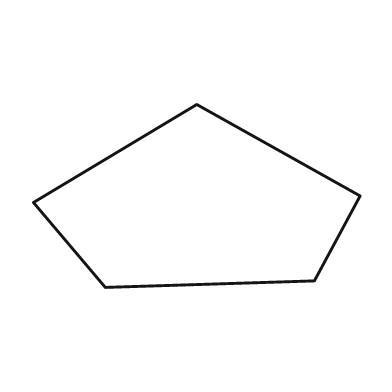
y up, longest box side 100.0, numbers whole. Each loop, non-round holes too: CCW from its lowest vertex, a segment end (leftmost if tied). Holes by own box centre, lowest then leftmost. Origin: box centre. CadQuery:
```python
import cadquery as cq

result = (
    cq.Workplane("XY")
    .moveTo(-28.0, -28.0)
    .lineTo(36.0, -26.0)
    .lineTo(50.0, 0.0)
    .lineTo(0.0, 28.0)
    .lineTo(-50.0, -2.0)
    .close()
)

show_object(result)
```